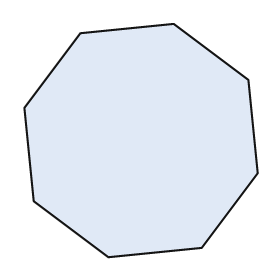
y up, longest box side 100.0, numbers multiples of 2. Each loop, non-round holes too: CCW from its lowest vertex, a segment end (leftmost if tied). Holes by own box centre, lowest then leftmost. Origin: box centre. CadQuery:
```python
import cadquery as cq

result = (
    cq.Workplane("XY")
    .moveTo(-14.0, -50.0)
    .lineTo(26.0, -46.0)
    .lineTo(50.0, -14.0)
    .lineTo(46.0, 26.0)
    .lineTo(14.0, 50.0)
    .lineTo(-26.0, 46.0)
    .lineTo(-50.0, 14.0)
    .lineTo(-46.0, -26.0)
    .close()
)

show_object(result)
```